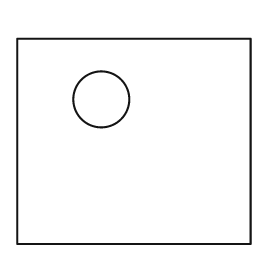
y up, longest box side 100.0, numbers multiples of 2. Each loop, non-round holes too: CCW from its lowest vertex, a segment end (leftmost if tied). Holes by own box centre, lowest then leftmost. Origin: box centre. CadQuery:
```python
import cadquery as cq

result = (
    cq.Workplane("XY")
    .moveTo(-50.0, -44.0)
    .lineTo(50.0, -44.0)
    .lineTo(50.0, 44.0)
    .lineTo(-50.0, 44.0)
    .close()
    .moveTo(-14.0, 18.0)
    .circle(12.0)
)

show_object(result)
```